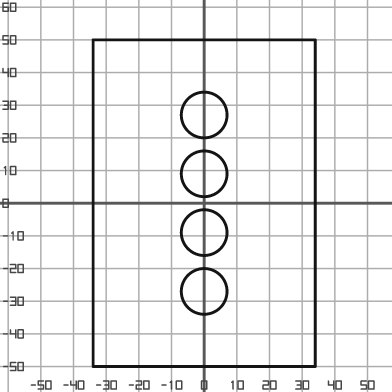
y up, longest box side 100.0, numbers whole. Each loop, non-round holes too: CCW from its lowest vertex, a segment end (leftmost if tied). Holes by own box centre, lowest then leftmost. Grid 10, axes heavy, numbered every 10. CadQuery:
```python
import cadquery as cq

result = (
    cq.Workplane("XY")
    .moveTo(-34.0, -50.0)
    .lineTo(34.0, -50.0)
    .lineTo(34.0, 50.0)
    .lineTo(-34.0, 50.0)
    .close()
    .moveTo(0.0, -27.0)
    .circle(7.0)
    .moveTo(0.0, -9.0)
    .circle(7.0)
    .moveTo(0.0, 9.0)
    .circle(7.0)
    .moveTo(0.0, 27.0)
    .circle(7.0)
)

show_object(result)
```